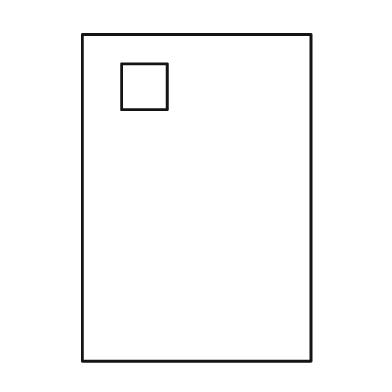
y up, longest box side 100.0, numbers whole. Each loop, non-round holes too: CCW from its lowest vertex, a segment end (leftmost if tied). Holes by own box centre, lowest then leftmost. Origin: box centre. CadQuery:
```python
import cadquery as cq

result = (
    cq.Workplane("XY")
    .moveTo(-35.0, -50.0)
    .lineTo(35.0, -50.0)
    .lineTo(35.0, 50.0)
    .lineTo(-35.0, 50.0)
    .close()
    .moveTo(-23.0, 27.0)
    .lineTo(-9.0, 27.0)
    .lineTo(-9.0, 41.0)
    .lineTo(-23.0, 41.0)
    .close()
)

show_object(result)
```